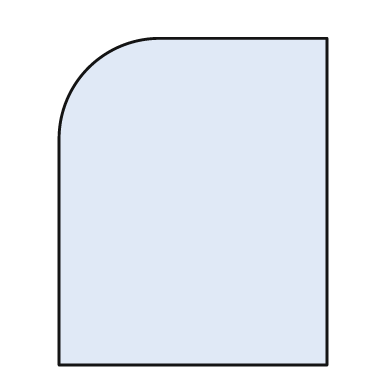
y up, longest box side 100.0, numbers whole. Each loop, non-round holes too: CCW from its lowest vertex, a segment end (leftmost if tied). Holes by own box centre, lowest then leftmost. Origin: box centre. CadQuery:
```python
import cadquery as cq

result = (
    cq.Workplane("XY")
    .moveTo(-41.0, -50.0)
    .lineTo(41.0, -50.0)
    .lineTo(41.0, 50.0)
    .lineTo(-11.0, 50.0)
    .threePointArc((-32.0, 41.0), (-41.0, 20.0))
    .close()
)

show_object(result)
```